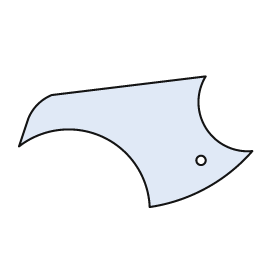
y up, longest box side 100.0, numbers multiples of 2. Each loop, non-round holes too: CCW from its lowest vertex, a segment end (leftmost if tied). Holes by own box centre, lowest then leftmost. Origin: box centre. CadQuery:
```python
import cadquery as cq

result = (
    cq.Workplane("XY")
    .moveTo(6.0, -28.0)
    .threePointArc((30.0, -20.0), (50.0, -4.0))
    .threePointArc((30.0, 6.0), (30.0, 28.0))
    .lineTo(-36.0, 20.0)
    .threePointArc((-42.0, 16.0), (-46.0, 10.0))
    .lineTo(-50.0, -2.0)
    .threePointArc((-14.0, 2.0), (6.0, -28.0))
    .close()
    .moveTo(28.0, -8.0)
    .circle(2.0)
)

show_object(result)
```